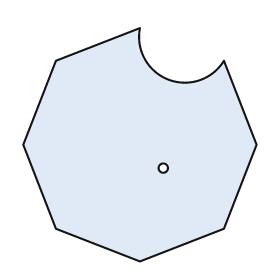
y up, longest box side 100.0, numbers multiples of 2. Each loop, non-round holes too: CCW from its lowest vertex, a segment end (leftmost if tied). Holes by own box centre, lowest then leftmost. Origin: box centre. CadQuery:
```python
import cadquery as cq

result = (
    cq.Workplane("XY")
    .moveTo(0.0, -50.0)
    .lineTo(36.0, -36.0)
    .lineTo(50.0, 0.0)
    .lineTo(36.0, 36.0)
    .threePointArc((12.0, 28.0), (0.0, 50.0))
    .lineTo(-36.0, 36.0)
    .lineTo(-50.0, 0.0)
    .lineTo(-36.0, -36.0)
    .close()
    .moveTo(10.0, -10.0)
    .circle(2.0)
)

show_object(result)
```